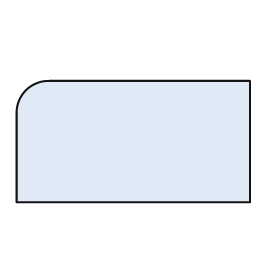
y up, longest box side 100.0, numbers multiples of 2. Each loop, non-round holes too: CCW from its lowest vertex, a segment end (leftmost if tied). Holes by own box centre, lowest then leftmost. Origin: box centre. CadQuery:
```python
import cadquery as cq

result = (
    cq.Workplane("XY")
    .moveTo(-50.0, -26.0)
    .lineTo(50.0, -26.0)
    .lineTo(50.0, 26.0)
    .lineTo(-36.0, 26.0)
    .threePointArc((-46.0, 22.0), (-50.0, 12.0))
    .close()
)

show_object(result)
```